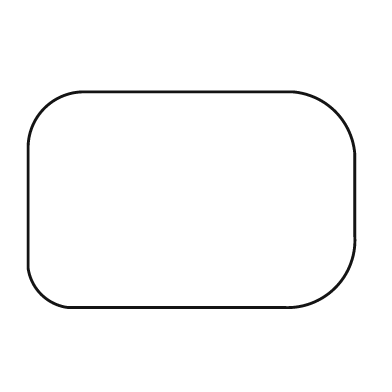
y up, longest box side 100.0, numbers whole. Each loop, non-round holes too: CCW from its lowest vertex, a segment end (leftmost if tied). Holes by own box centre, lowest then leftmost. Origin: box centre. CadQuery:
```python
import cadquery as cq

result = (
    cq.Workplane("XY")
    .moveTo(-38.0, -33.0)
    .lineTo(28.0, -33.0)
    .threePointArc((44.0, -27.0), (50.0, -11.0))
    .lineTo(50.0, 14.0)
    .threePointArc((44.0, 27.0), (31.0, 33.0))
    .lineTo(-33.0, 33.0)
    .threePointArc((-45.0, 28.0), (-50.0, 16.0))
    .lineTo(-50.0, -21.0)
    .threePointArc((-46.0, -29.0), (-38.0, -33.0))
    .close()
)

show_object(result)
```